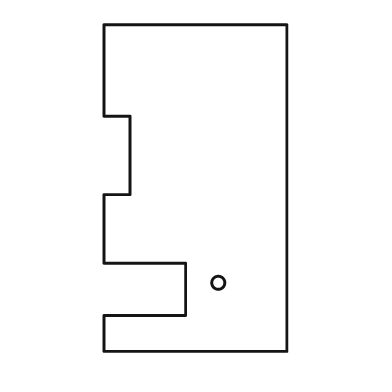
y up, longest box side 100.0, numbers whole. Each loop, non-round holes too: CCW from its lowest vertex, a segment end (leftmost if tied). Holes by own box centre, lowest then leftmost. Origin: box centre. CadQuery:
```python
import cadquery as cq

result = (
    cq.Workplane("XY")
    .moveTo(-28.0, -50.0)
    .lineTo(28.0, -50.0)
    .lineTo(28.0, 50.0)
    .lineTo(-28.0, 50.0)
    .lineTo(-28.0, 22.0)
    .lineTo(-20.0, 22.0)
    .lineTo(-20.0, -2.0)
    .lineTo(-28.0, -2.0)
    .lineTo(-28.0, -23.0)
    .lineTo(-3.0, -23.0)
    .lineTo(-3.0, -39.0)
    .lineTo(-28.0, -39.0)
    .close()
    .moveTo(7.0, -29.0)
    .circle(2.0)
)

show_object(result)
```